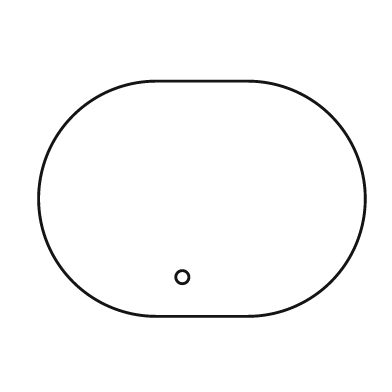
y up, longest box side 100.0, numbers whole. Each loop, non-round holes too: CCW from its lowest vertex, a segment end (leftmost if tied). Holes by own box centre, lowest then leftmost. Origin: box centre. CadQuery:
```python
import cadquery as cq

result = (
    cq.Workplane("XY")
    .moveTo(-14.0, -36.0)
    .lineTo(14.0, -36.0)
    .threePointArc((50.0, 0.0), (14.0, 36.0))
    .lineTo(-14.0, 36.0)
    .threePointArc((-50.0, 0.0), (-14.0, -36.0))
    .close()
    .moveTo(-6.0, -24.0)
    .circle(2.0)
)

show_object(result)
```